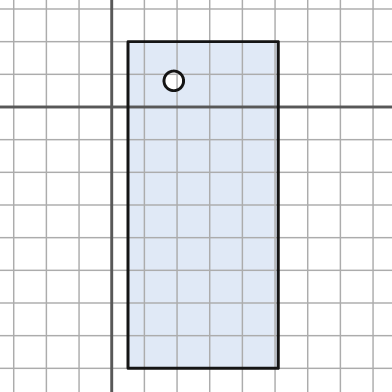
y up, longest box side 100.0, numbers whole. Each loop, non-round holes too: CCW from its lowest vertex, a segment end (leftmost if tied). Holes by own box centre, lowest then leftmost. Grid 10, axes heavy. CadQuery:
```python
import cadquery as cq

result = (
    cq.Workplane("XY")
    .moveTo(5.0, -80.0)
    .lineTo(51.0, -80.0)
    .lineTo(51.0, 20.0)
    .lineTo(5.0, 20.0)
    .close()
    .moveTo(19.0, 8.0)
    .circle(3.0)
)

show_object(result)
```